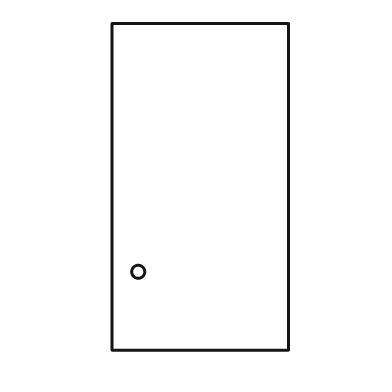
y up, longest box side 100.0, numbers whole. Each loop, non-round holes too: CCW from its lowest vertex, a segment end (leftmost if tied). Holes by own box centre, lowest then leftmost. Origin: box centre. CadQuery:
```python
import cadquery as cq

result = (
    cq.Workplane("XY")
    .moveTo(-27.0, -50.0)
    .lineTo(27.0, -50.0)
    .lineTo(27.0, 50.0)
    .lineTo(-27.0, 50.0)
    .close()
    .moveTo(-19.0, -26.0)
    .circle(2.0)
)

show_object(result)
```